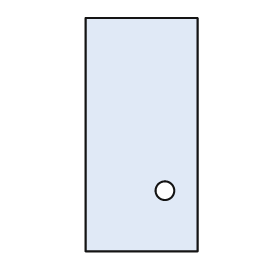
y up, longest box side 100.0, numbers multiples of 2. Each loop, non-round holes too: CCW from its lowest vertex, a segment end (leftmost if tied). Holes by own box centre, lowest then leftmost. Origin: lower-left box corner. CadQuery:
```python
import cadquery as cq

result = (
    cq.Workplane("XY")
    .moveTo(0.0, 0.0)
    .lineTo(48.0, 0.0)
    .lineTo(48.0, 100.0)
    .lineTo(0.0, 100.0)
    .close()
    .moveTo(34.0, 26.0)
    .circle(4.0)
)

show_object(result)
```